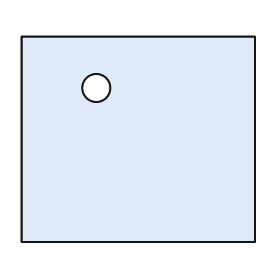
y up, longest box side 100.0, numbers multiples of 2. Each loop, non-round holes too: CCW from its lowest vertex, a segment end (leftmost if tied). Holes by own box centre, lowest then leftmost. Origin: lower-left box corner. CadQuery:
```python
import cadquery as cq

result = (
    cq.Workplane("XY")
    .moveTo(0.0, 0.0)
    .lineTo(100.0, 0.0)
    .lineTo(100.0, 88.0)
    .lineTo(0.0, 88.0)
    .close()
    .moveTo(32.0, 66.0)
    .circle(6.0)
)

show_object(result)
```